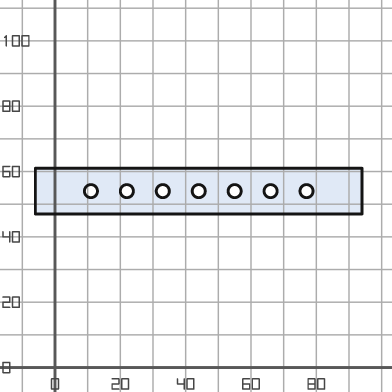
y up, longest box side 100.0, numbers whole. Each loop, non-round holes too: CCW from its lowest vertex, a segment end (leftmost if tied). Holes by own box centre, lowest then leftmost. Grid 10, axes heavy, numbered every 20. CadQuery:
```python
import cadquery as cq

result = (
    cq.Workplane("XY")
    .moveTo(-6.0, 47.0)
    .lineTo(94.0, 47.0)
    .lineTo(94.0, 61.0)
    .lineTo(-6.0, 61.0)
    .close()
    .moveTo(11.0, 54.0)
    .circle(2.0)
    .moveTo(22.0, 54.0)
    .circle(2.0)
    .moveTo(33.0, 54.0)
    .circle(2.0)
    .moveTo(44.0, 54.0)
    .circle(2.0)
    .moveTo(55.0, 54.0)
    .circle(2.0)
    .moveTo(66.0, 54.0)
    .circle(2.0)
    .moveTo(77.0, 54.0)
    .circle(2.0)
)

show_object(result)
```